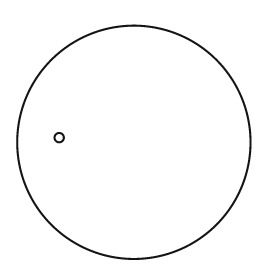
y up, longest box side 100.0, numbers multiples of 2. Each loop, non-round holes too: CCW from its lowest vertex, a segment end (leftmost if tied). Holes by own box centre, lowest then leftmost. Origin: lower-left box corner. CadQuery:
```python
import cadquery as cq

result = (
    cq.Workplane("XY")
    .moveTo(50.0, 50.0)
    .circle(50.0)
    .moveTo(18.0, 52.0)
    .circle(2.0)
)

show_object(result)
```